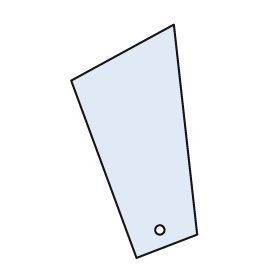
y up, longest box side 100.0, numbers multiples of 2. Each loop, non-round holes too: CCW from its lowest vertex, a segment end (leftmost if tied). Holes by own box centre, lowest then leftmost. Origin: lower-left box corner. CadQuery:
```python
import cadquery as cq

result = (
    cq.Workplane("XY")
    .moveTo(28.0, 0.0)
    .lineTo(54.0, 10.0)
    .lineTo(44.0, 100.0)
    .lineTo(0.0, 76.0)
    .close()
    .moveTo(38.0, 12.0)
    .circle(2.0)
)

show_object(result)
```